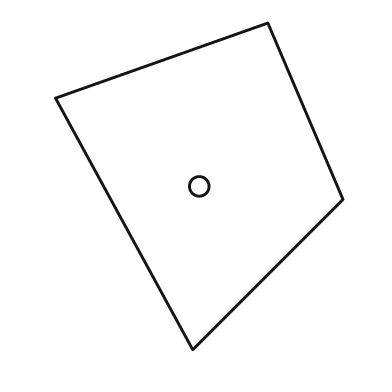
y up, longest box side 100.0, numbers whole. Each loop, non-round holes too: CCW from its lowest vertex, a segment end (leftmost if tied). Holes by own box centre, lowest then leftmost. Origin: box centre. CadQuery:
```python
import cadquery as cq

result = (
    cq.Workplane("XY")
    .moveTo(-2.0, -50.0)
    .lineTo(44.0, -4.0)
    .lineTo(21.0, 50.0)
    .lineTo(-44.0, 27.0)
    .close()
    .moveTo(0.0, 0.0)
    .circle(3.0)
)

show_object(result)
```